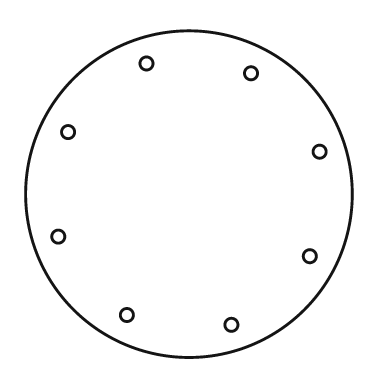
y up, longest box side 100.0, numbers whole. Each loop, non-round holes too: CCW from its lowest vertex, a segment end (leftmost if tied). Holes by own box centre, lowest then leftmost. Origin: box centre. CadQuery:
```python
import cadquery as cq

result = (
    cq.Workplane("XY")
    .moveTo(0.0, 0.0)
    .circle(50.0)
    .moveTo(13.0, -40.0)
    .circle(2.0)
    .moveTo(-19.0, -37.0)
    .circle(2.0)
    .moveTo(37.0, -19.0)
    .circle(2.0)
    .moveTo(-40.0, -13.0)
    .circle(2.0)
    .moveTo(40.0, 13.0)
    .circle(2.0)
    .moveTo(-37.0, 19.0)
    .circle(2.0)
    .moveTo(19.0, 37.0)
    .circle(2.0)
    .moveTo(-13.0, 40.0)
    .circle(2.0)
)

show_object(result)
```